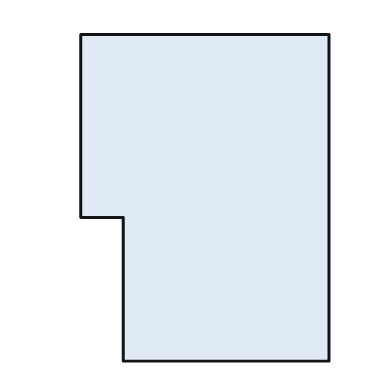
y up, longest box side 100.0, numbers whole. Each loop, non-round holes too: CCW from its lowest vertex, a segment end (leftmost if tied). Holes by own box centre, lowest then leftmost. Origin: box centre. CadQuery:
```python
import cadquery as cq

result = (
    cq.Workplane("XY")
    .moveTo(-25.0, -50.0)
    .lineTo(38.0, -50.0)
    .lineTo(38.0, 50.0)
    .lineTo(-38.0, 50.0)
    .lineTo(-38.0, -6.0)
    .lineTo(-25.0, -6.0)
    .close()
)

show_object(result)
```